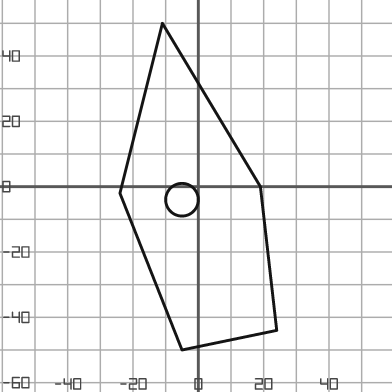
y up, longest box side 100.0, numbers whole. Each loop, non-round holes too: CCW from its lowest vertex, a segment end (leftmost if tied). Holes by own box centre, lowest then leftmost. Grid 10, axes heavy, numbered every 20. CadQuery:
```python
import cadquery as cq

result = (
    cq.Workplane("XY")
    .moveTo(-5.0, -50.0)
    .lineTo(24.0, -44.0)
    .lineTo(19.0, 0.0)
    .lineTo(-11.0, 50.0)
    .lineTo(-24.0, -2.0)
    .close()
    .moveTo(-5.0, -4.0)
    .circle(5.0)
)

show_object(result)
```